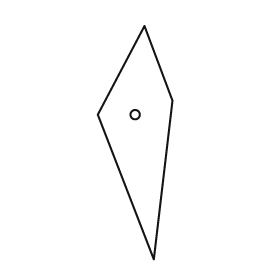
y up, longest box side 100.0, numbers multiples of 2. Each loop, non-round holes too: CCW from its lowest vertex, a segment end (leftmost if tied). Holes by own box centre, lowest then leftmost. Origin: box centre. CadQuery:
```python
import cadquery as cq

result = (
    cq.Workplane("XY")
    .moveTo(8.0, -50.0)
    .lineTo(16.0, 18.0)
    .lineTo(4.0, 50.0)
    .lineTo(-16.0, 12.0)
    .close()
    .moveTo(0.0, 12.0)
    .circle(2.0)
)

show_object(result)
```